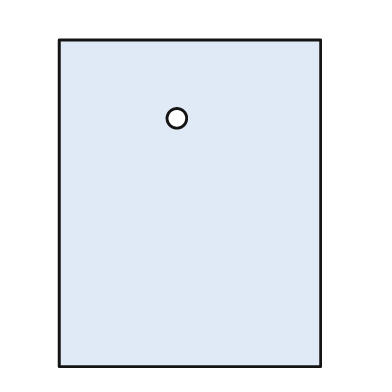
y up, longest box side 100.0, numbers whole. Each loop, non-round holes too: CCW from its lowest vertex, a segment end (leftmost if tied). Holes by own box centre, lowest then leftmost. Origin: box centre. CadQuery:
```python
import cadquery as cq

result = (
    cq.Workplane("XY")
    .moveTo(-40.0, -50.0)
    .lineTo(40.0, -50.0)
    .lineTo(40.0, 50.0)
    .lineTo(-40.0, 50.0)
    .close()
    .moveTo(-4.0, 26.0)
    .circle(3.0)
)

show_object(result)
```